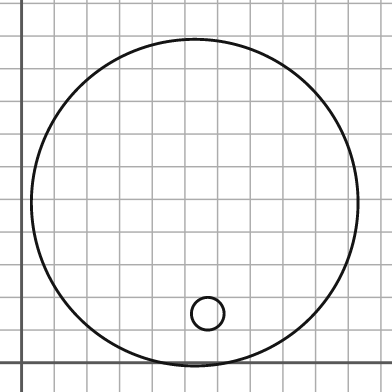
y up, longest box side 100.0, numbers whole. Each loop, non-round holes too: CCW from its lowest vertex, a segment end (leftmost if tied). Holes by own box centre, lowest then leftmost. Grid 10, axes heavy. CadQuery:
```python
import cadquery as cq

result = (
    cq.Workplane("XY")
    .moveTo(53.0, 49.0)
    .circle(50.0)
    .moveTo(57.0, 15.0)
    .circle(5.0)
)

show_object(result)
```